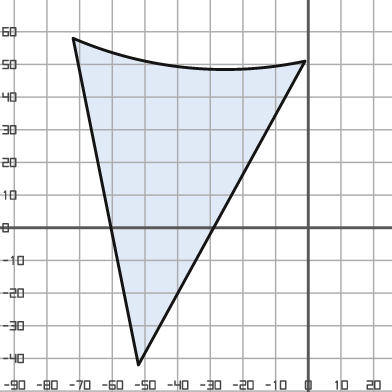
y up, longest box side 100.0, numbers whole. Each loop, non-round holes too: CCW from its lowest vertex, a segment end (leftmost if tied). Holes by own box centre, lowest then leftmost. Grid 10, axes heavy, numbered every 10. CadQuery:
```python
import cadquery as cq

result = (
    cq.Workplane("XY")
    .moveTo(-52.0, -42.0)
    .lineTo(-1.0, 51.0)
    .threePointArc((-37.0, 49.0), (-72.0, 58.0))
    .close()
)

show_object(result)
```